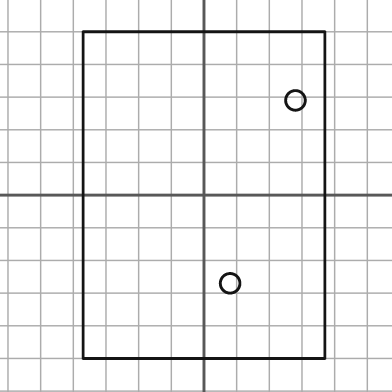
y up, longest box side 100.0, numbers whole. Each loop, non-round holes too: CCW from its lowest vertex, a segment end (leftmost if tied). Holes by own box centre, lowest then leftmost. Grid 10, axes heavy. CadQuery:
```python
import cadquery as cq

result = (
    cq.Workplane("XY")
    .moveTo(-37.0, -50.0)
    .lineTo(37.0, -50.0)
    .lineTo(37.0, 50.0)
    .lineTo(-37.0, 50.0)
    .close()
    .moveTo(8.0, -27.0)
    .circle(3.0)
    .moveTo(28.0, 29.0)
    .circle(3.0)
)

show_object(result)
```